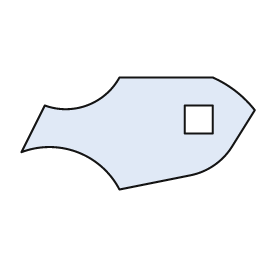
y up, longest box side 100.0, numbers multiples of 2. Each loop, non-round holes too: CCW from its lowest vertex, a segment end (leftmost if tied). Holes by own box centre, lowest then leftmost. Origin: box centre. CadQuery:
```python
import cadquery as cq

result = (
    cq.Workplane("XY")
    .moveTo(-8.0, -24.0)
    .lineTo(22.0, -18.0)
    .threePointArc((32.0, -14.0), (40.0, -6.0))
    .lineTo(50.0, 10.0)
    .threePointArc((42.0, 18.0), (32.0, 24.0))
    .lineTo(-8.0, 24.0)
    .threePointArc((-22.0, 12.0), (-40.0, 12.0))
    .lineTo(-50.0, -8.0)
    .threePointArc((-26.0, -8.0), (-8.0, -24.0))
    .close()
    .moveTo(20.0, 0.0)
    .lineTo(32.0, 0.0)
    .lineTo(32.0, 12.0)
    .lineTo(20.0, 12.0)
    .close()
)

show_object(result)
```